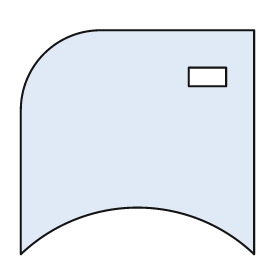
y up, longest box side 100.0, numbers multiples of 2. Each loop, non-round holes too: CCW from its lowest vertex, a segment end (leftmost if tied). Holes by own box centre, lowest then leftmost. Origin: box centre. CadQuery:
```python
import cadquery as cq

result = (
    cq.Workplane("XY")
    .moveTo(-50.0, -48.0)
    .threePointArc((0.0, -28.0), (50.0, -48.0))
    .lineTo(50.0, 48.0)
    .lineTo(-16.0, 48.0)
    .threePointArc((-40.0, 38.0), (-50.0, 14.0))
    .close()
    .moveTo(22.0, 24.0)
    .lineTo(38.0, 24.0)
    .lineTo(38.0, 32.0)
    .lineTo(22.0, 32.0)
    .close()
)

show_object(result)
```